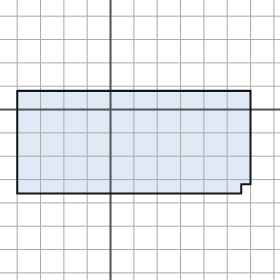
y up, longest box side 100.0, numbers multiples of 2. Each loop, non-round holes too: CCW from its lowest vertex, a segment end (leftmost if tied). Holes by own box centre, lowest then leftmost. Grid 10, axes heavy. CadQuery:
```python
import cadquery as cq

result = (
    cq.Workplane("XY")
    .moveTo(-40.0, -36.0)
    .lineTo(56.0, -36.0)
    .lineTo(56.0, -32.0)
    .lineTo(60.0, -32.0)
    .lineTo(60.0, 8.0)
    .lineTo(-40.0, 8.0)
    .close()
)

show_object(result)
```